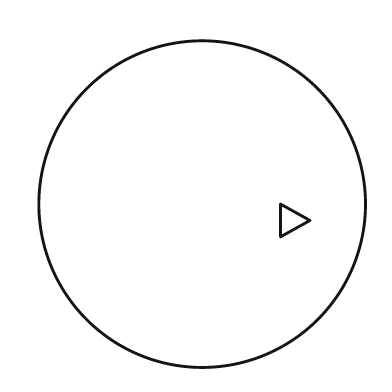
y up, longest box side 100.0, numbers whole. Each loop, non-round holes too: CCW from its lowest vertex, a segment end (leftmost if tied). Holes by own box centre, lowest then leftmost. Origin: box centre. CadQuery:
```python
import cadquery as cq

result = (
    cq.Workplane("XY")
    .moveTo(0.0, 0.0)
    .circle(50.0)
    .moveTo(24.0, -10.0)
    .lineTo(33.0, -5.0)
    .lineTo(24.0, 0.0)
    .close()
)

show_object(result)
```